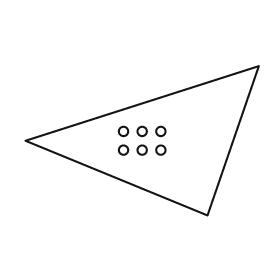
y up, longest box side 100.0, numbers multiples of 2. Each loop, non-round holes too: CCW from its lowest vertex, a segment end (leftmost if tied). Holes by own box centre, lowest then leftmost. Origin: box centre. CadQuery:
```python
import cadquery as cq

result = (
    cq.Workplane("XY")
    .moveTo(28.0, -32.0)
    .lineTo(50.0, 32.0)
    .lineTo(-50.0, 0.0)
    .close()
    .moveTo(-8.0, -4.0)
    .circle(2.0)
    .moveTo(0.0, -4.0)
    .circle(2.0)
    .moveTo(8.0, -4.0)
    .circle(2.0)
    .moveTo(-8.0, 4.0)
    .circle(2.0)
    .moveTo(0.0, 4.0)
    .circle(2.0)
    .moveTo(8.0, 4.0)
    .circle(2.0)
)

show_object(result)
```